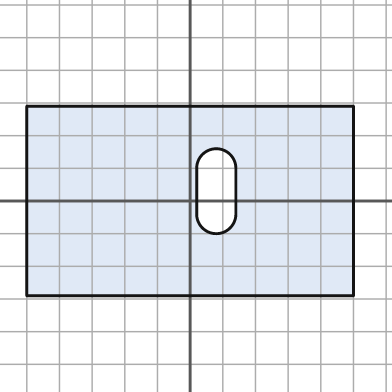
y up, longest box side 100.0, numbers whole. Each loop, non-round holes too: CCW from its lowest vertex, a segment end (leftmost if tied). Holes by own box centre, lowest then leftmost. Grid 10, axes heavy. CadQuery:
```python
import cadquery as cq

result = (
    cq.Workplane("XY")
    .moveTo(-50.0, -29.0)
    .lineTo(50.0, -29.0)
    .lineTo(50.0, 29.0)
    .lineTo(-50.0, 29.0)
    .close()
    .moveTo(2.0, -4.0)
    .threePointArc((8.0, -10.0), (14.0, -4.0))
    .lineTo(14.0, 10.0)
    .threePointArc((8.0, 16.0), (2.0, 10.0))
    .close()
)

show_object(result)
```